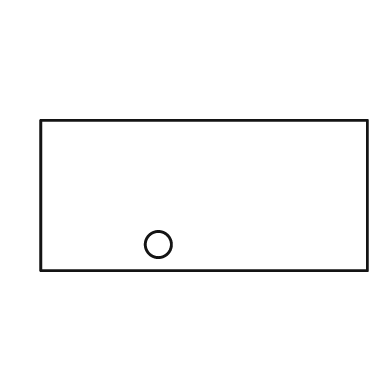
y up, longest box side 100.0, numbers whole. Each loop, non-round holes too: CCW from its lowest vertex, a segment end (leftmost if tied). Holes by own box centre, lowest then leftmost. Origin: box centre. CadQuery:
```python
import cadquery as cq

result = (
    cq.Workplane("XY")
    .moveTo(-50.0, -23.0)
    .lineTo(50.0, -23.0)
    .lineTo(50.0, 23.0)
    .lineTo(-50.0, 23.0)
    .close()
    .moveTo(-14.0, -15.0)
    .circle(4.0)
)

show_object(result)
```